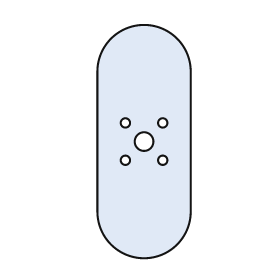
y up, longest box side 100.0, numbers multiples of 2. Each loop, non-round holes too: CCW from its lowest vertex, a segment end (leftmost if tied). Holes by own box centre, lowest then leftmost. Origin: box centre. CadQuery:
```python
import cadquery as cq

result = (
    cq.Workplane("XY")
    .moveTo(-20.0, -30.0)
    .threePointArc((0.0, -50.0), (20.0, -30.0))
    .lineTo(20.0, 30.0)
    .threePointArc((0.0, 50.0), (-20.0, 30.0))
    .close()
    .moveTo(-8.0, -8.0)
    .circle(2.0)
    .moveTo(8.0, -8.0)
    .circle(2.0)
    .moveTo(0.0, 0.0)
    .circle(4.0)
    .moveTo(-8.0, 8.0)
    .circle(2.0)
    .moveTo(8.0, 8.0)
    .circle(2.0)
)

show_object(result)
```